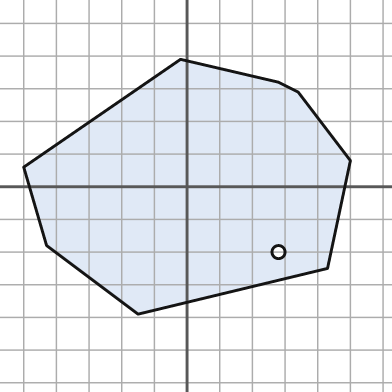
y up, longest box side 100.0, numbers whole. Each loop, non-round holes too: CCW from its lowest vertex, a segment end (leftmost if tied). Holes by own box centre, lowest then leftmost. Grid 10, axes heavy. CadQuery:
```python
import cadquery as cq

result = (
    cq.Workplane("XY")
    .moveTo(-15.0, -39.0)
    .lineTo(43.0, -25.0)
    .lineTo(50.0, 8.0)
    .lineTo(34.0, 29.0)
    .lineTo(28.0, 32.0)
    .lineTo(-2.0, 39.0)
    .lineTo(-50.0, 6.0)
    .lineTo(-43.0, -18.0)
    .close()
    .moveTo(28.0, -20.0)
    .circle(2.0)
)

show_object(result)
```